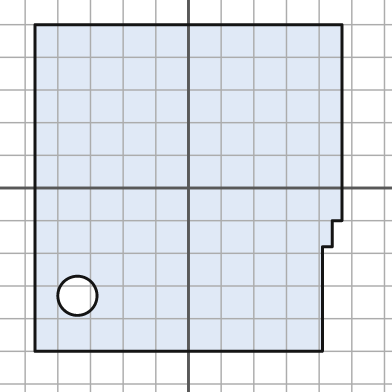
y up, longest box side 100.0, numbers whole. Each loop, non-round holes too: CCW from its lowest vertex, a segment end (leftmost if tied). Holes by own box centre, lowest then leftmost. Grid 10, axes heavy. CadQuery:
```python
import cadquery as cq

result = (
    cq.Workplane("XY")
    .moveTo(-47.0, -50.0)
    .lineTo(41.0, -50.0)
    .lineTo(41.0, -18.0)
    .lineTo(44.0, -18.0)
    .lineTo(44.0, -10.0)
    .lineTo(47.0, -10.0)
    .lineTo(47.0, 50.0)
    .lineTo(-47.0, 50.0)
    .close()
    .moveTo(-34.0, -33.0)
    .circle(6.0)
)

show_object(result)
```